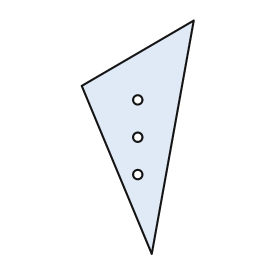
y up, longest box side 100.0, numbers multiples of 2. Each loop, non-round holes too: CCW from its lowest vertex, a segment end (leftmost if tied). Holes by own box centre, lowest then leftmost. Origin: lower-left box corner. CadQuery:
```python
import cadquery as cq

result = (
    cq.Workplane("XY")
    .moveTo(30.0, 0.0)
    .lineTo(48.0, 100.0)
    .lineTo(0.0, 72.0)
    .close()
    .moveTo(24.0, 34.0)
    .circle(2.0)
    .moveTo(24.0, 50.0)
    .circle(2.0)
    .moveTo(24.0, 66.0)
    .circle(2.0)
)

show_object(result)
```